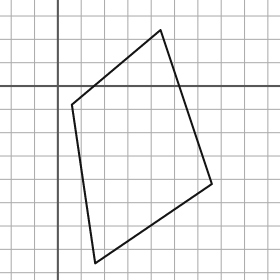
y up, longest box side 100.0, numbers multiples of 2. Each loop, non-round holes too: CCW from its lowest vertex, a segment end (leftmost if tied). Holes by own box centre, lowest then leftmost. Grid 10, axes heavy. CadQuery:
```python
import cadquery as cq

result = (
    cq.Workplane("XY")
    .moveTo(16.0, -76.0)
    .lineTo(66.0, -42.0)
    .lineTo(44.0, 24.0)
    .lineTo(6.0, -8.0)
    .close()
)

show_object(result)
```